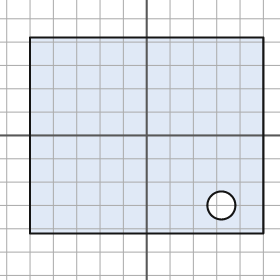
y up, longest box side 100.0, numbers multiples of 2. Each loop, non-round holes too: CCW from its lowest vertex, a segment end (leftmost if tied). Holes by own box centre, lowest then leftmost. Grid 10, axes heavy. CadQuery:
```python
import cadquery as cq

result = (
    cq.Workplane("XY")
    .moveTo(-50.0, -42.0)
    .lineTo(50.0, -42.0)
    .lineTo(50.0, 42.0)
    .lineTo(-50.0, 42.0)
    .close()
    .moveTo(32.0, -30.0)
    .circle(6.0)
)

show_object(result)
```